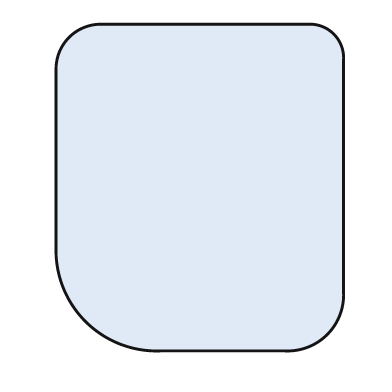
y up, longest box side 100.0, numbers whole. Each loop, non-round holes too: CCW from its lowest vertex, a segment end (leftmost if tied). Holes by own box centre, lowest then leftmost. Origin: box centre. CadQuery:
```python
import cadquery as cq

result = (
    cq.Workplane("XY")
    .moveTo(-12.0, -50.0)
    .lineTo(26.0, -50.0)
    .threePointArc((39.0, -45.0), (44.0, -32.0))
    .lineTo(44.0, 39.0)
    .threePointArc((41.0, 47.0), (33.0, 50.0))
    .lineTo(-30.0, 50.0)
    .threePointArc((-40.0, 46.0), (-44.0, 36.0))
    .lineTo(-44.0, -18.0)
    .threePointArc((-35.0, -41.0), (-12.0, -50.0))
    .close()
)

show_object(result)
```